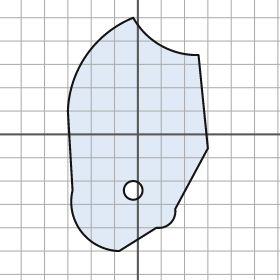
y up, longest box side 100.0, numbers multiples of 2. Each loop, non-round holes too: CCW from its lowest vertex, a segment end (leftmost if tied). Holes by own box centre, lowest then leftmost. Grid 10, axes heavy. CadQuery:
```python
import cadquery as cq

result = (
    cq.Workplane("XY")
    .moveTo(-8.0, -50.0)
    .lineTo(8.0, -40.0)
    .threePointArc((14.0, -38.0), (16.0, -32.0))
    .lineTo(30.0, -6.0)
    .lineTo(26.0, 34.0)
    .threePointArc((10.0, 38.0), (-2.0, 50.0))
    .threePointArc((-22.0, 34.0), (-30.0, 10.0))
    .lineTo(-28.0, -24.0)
    .threePointArc((-24.0, -42.0), (-8.0, -50.0))
    .close()
    .moveTo(-2.0, -24.0)
    .circle(4.0)
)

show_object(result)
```